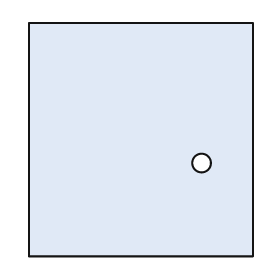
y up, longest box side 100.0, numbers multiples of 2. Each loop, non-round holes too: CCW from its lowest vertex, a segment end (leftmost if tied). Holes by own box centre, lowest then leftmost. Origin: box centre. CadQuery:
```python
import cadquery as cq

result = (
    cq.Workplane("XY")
    .moveTo(-48.0, -50.0)
    .lineTo(48.0, -50.0)
    .lineTo(48.0, 50.0)
    .lineTo(-48.0, 50.0)
    .close()
    .moveTo(26.0, -10.0)
    .circle(4.0)
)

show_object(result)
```